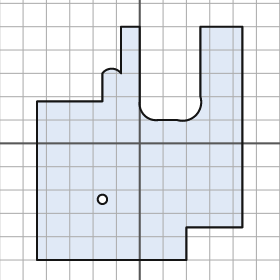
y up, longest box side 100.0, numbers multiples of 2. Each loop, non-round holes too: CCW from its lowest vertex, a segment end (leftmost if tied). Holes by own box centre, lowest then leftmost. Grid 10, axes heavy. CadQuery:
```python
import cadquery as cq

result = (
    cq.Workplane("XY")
    .moveTo(-44.0, -50.0)
    .lineTo(20.0, -50.0)
    .lineTo(20.0, -36.0)
    .lineTo(44.0, -36.0)
    .lineTo(44.0, 50.0)
    .lineTo(26.0, 50.0)
    .lineTo(26.0, 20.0)
    .threePointArc((24.0, 12.0), (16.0, 10.0))
    .lineTo(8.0, 10.0)
    .threePointArc((2.0, 12.0), (0.0, 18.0))
    .lineTo(0.0, 50.0)
    .lineTo(-8.0, 50.0)
    .lineTo(-8.0, 30.0)
    .threePointArc((-12.0, 32.0), (-16.0, 30.0))
    .lineTo(-16.0, 18.0)
    .lineTo(-44.0, 18.0)
    .close()
    .moveTo(-16.0, -24.0)
    .circle(2.0)
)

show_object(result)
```